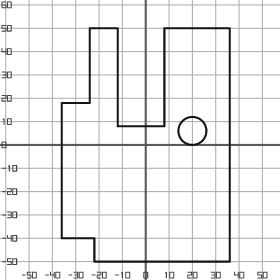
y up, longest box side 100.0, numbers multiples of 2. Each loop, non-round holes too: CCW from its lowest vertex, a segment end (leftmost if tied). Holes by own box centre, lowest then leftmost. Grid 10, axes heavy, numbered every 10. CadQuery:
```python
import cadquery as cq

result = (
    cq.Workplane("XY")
    .moveTo(-22.0, -50.0)
    .lineTo(36.0, -50.0)
    .lineTo(36.0, 50.0)
    .lineTo(8.0, 50.0)
    .lineTo(8.0, 8.0)
    .lineTo(-12.0, 8.0)
    .lineTo(-12.0, 50.0)
    .lineTo(-24.0, 50.0)
    .lineTo(-24.0, 18.0)
    .lineTo(-36.0, 18.0)
    .lineTo(-36.0, -40.0)
    .lineTo(-22.0, -40.0)
    .close()
    .moveTo(20.0, 6.0)
    .circle(6.0)
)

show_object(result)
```